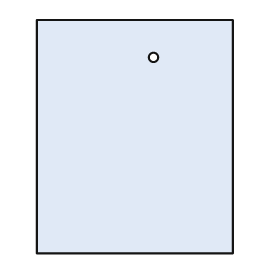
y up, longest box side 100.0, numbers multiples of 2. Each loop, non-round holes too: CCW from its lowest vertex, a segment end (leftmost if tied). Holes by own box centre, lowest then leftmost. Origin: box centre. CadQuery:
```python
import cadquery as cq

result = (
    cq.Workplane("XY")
    .moveTo(-42.0, -50.0)
    .lineTo(42.0, -50.0)
    .lineTo(42.0, 50.0)
    .lineTo(-42.0, 50.0)
    .close()
    .moveTo(8.0, 34.0)
    .circle(2.0)
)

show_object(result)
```